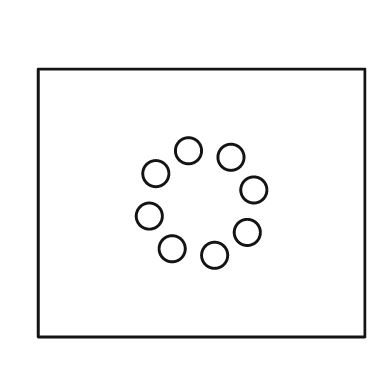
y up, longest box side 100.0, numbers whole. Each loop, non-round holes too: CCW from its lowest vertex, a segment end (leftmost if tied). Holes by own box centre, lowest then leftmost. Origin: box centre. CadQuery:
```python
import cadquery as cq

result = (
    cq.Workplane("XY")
    .moveTo(-50.0, -41.0)
    .lineTo(50.0, -41.0)
    .lineTo(50.0, 41.0)
    .lineTo(-50.0, 41.0)
    .close()
    .moveTo(4.0, -16.0)
    .circle(4.0)
    .moveTo(-9.0, -14.0)
    .circle(4.0)
    .moveTo(14.0, -9.0)
    .circle(4.0)
    .moveTo(-16.0, -4.0)
    .circle(4.0)
    .moveTo(16.0, 4.0)
    .circle(4.0)
    .moveTo(-14.0, 9.0)
    .circle(4.0)
    .moveTo(9.0, 14.0)
    .circle(4.0)
    .moveTo(-4.0, 16.0)
    .circle(4.0)
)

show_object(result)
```